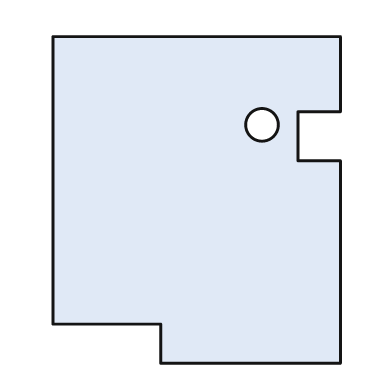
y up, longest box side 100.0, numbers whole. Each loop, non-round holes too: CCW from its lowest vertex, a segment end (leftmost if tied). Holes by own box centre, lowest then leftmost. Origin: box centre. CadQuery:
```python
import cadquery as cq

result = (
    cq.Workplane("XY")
    .moveTo(-11.0, -50.0)
    .lineTo(44.0, -50.0)
    .lineTo(44.0, 12.0)
    .lineTo(31.0, 12.0)
    .lineTo(31.0, 27.0)
    .lineTo(44.0, 27.0)
    .lineTo(44.0, 50.0)
    .lineTo(-44.0, 50.0)
    .lineTo(-44.0, -38.0)
    .lineTo(-11.0, -38.0)
    .close()
    .moveTo(20.0, 23.0)
    .circle(5.0)
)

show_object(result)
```